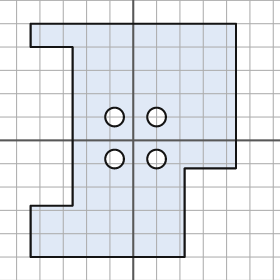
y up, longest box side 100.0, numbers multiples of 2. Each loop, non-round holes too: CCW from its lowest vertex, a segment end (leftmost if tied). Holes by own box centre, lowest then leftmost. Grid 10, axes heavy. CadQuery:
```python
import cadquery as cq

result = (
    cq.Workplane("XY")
    .moveTo(-44.0, -50.0)
    .lineTo(22.0, -50.0)
    .lineTo(22.0, -12.0)
    .lineTo(44.0, -12.0)
    .lineTo(44.0, 50.0)
    .lineTo(-44.0, 50.0)
    .lineTo(-44.0, 40.0)
    .lineTo(-26.0, 40.0)
    .lineTo(-26.0, -28.0)
    .lineTo(-44.0, -28.0)
    .close()
    .moveTo(-8.0, -8.0)
    .circle(4.0)
    .moveTo(10.0, -8.0)
    .circle(4.0)
    .moveTo(-8.0, 10.0)
    .circle(4.0)
    .moveTo(10.0, 10.0)
    .circle(4.0)
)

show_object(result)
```